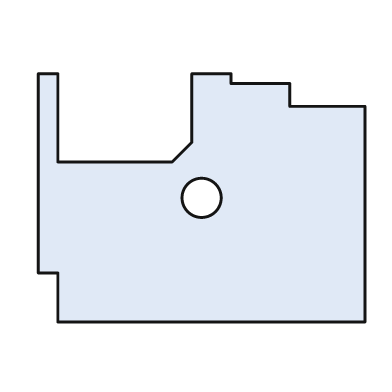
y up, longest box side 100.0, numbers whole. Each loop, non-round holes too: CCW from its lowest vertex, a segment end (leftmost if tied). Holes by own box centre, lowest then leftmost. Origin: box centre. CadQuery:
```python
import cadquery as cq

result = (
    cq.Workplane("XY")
    .moveTo(-44.0, -38.0)
    .lineTo(50.0, -38.0)
    .lineTo(50.0, 28.0)
    .lineTo(27.0, 28.0)
    .lineTo(27.0, 35.0)
    .lineTo(9.0, 35.0)
    .lineTo(9.0, 38.0)
    .lineTo(-3.0, 38.0)
    .lineTo(-3.0, 17.0)
    .lineTo(-9.0, 11.0)
    .lineTo(-44.0, 11.0)
    .lineTo(-44.0, 38.0)
    .lineTo(-50.0, 38.0)
    .lineTo(-50.0, -23.0)
    .lineTo(-44.0, -23.0)
    .close()
    .moveTo(0.0, 0.0)
    .circle(6.0)
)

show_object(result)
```